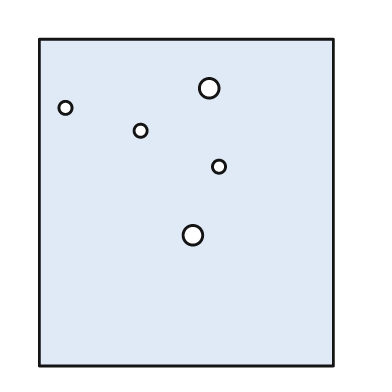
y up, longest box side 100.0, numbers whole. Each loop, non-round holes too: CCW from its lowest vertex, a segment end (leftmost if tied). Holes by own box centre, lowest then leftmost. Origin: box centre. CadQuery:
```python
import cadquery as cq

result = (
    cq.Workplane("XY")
    .moveTo(-45.0, -50.0)
    .lineTo(45.0, -50.0)
    .lineTo(45.0, 50.0)
    .lineTo(-45.0, 50.0)
    .close()
    .moveTo(2.0, -10.0)
    .circle(3.0)
    .moveTo(10.0, 11.0)
    .circle(2.0)
    .moveTo(-14.0, 22.0)
    .circle(2.0)
    .moveTo(-37.0, 29.0)
    .circle(2.0)
    .moveTo(7.0, 35.0)
    .circle(3.0)
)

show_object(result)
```